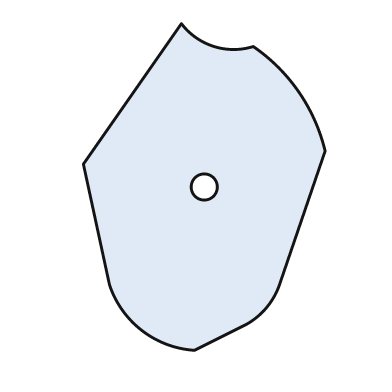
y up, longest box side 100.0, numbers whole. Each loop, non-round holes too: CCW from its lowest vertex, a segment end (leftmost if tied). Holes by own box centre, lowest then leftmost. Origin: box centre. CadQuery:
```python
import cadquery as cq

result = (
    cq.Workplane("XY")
    .moveTo(-3.0, -50.0)
    .lineTo(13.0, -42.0)
    .threePointArc((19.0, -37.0), (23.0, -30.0))
    .lineTo(37.0, 11.0)
    .threePointArc((29.0, 29.0), (15.0, 43.0))
    .threePointArc((3.0, 43.0), (-7.0, 50.0))
    .lineTo(-37.0, 7.0)
    .lineTo(-29.0, -30.0)
    .threePointArc((-19.0, -44.0), (-3.0, -50.0))
    .close()
    .moveTo(0.0, 0.0)
    .circle(4.0)
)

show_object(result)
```